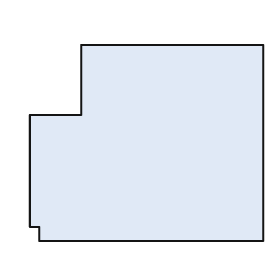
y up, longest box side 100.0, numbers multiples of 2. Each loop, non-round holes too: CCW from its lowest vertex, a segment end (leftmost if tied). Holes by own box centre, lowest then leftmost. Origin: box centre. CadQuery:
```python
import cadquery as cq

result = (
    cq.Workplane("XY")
    .moveTo(-46.0, -42.0)
    .lineTo(50.0, -42.0)
    .lineTo(50.0, 42.0)
    .lineTo(-28.0, 42.0)
    .lineTo(-28.0, 12.0)
    .lineTo(-50.0, 12.0)
    .lineTo(-50.0, -36.0)
    .lineTo(-46.0, -36.0)
    .close()
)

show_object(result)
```